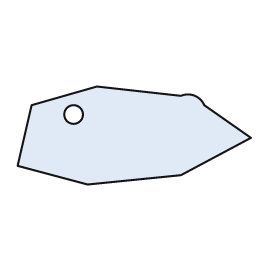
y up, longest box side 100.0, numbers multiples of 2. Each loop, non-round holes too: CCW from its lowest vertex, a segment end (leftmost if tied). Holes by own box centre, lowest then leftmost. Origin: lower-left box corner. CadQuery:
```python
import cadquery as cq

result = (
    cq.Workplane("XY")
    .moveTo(30.0, 0.0)
    .lineTo(70.0, 4.0)
    .lineTo(100.0, 20.0)
    .lineTo(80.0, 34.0)
    .threePointArc((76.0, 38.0), (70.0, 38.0))
    .lineTo(34.0, 42.0)
    .lineTo(6.0, 34.0)
    .lineTo(0.0, 8.0)
    .close()
    .moveTo(24.0, 30.0)
    .circle(4.0)
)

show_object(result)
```